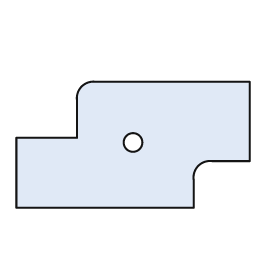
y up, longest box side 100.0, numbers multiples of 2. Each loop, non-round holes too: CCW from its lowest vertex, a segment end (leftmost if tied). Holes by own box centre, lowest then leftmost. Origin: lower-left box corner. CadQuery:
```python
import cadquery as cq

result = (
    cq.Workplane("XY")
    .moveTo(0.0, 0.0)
    .lineTo(76.0, 0.0)
    .lineTo(76.0, 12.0)
    .threePointArc((78.0, 18.0), (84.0, 20.0))
    .lineTo(100.0, 20.0)
    .lineTo(100.0, 54.0)
    .lineTo(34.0, 54.0)
    .threePointArc((28.0, 52.0), (26.0, 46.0))
    .lineTo(26.0, 30.0)
    .lineTo(0.0, 30.0)
    .close()
    .moveTo(50.0, 28.0)
    .circle(4.0)
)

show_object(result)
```